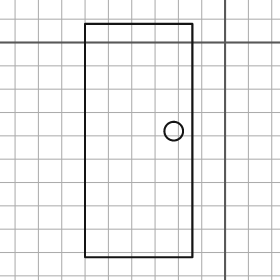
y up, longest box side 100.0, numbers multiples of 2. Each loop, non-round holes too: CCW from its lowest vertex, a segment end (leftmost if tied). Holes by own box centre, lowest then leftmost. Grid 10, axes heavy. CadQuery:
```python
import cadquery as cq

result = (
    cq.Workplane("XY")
    .moveTo(-60.0, -92.0)
    .lineTo(-14.0, -92.0)
    .lineTo(-14.0, 8.0)
    .lineTo(-60.0, 8.0)
    .close()
    .moveTo(-22.0, -38.0)
    .circle(4.0)
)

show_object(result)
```